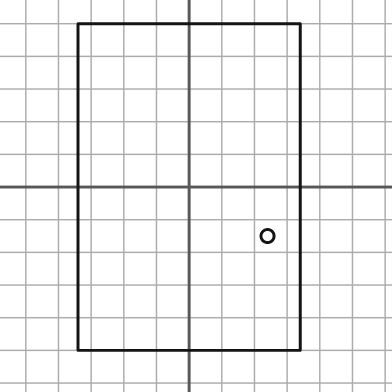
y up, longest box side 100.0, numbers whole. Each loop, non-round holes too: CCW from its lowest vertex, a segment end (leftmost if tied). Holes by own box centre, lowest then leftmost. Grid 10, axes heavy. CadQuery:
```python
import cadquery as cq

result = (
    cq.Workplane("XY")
    .moveTo(-34.0, -50.0)
    .lineTo(34.0, -50.0)
    .lineTo(34.0, 50.0)
    .lineTo(-34.0, 50.0)
    .close()
    .moveTo(24.0, -15.0)
    .circle(2.0)
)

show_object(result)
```